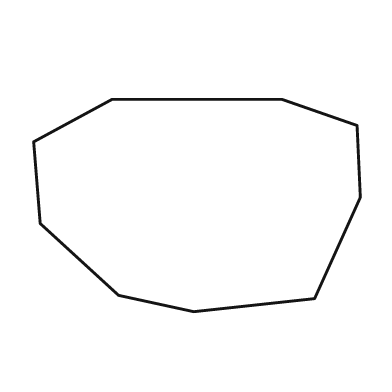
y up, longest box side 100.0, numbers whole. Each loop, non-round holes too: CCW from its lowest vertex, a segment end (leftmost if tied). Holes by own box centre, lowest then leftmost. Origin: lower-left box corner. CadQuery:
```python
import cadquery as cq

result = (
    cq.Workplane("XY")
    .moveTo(49.0, 0.0)
    .lineTo(86.0, 4.0)
    .lineTo(100.0, 35.0)
    .lineTo(99.0, 57.0)
    .lineTo(76.0, 65.0)
    .lineTo(24.0, 65.0)
    .lineTo(0.0, 52.0)
    .lineTo(2.0, 27.0)
    .lineTo(26.0, 5.0)
    .close()
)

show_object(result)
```